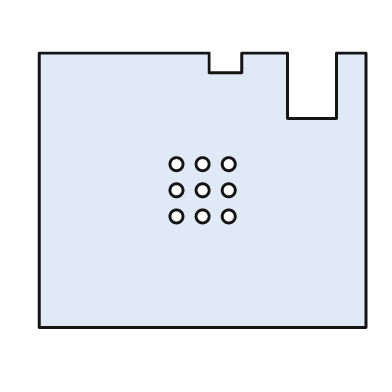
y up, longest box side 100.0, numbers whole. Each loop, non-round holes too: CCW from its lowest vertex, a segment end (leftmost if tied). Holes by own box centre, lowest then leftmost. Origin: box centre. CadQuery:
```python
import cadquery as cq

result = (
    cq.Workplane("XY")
    .moveTo(-50.0, -42.0)
    .lineTo(50.0, -42.0)
    .lineTo(50.0, 42.0)
    .lineTo(41.0, 42.0)
    .lineTo(41.0, 22.0)
    .lineTo(26.0, 22.0)
    .lineTo(26.0, 42.0)
    .lineTo(12.0, 42.0)
    .lineTo(12.0, 36.0)
    .lineTo(2.0, 36.0)
    .lineTo(2.0, 42.0)
    .lineTo(-50.0, 42.0)
    .close()
    .moveTo(-8.0, -8.0)
    .circle(2.0)
    .moveTo(0.0, -8.0)
    .circle(2.0)
    .moveTo(8.0, -8.0)
    .circle(2.0)
    .moveTo(-8.0, 0.0)
    .circle(2.0)
    .moveTo(0.0, 0.0)
    .circle(2.0)
    .moveTo(8.0, 0.0)
    .circle(2.0)
    .moveTo(-8.0, 8.0)
    .circle(2.0)
    .moveTo(0.0, 8.0)
    .circle(2.0)
    .moveTo(8.0, 8.0)
    .circle(2.0)
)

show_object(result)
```